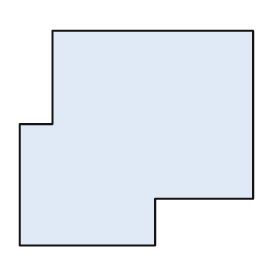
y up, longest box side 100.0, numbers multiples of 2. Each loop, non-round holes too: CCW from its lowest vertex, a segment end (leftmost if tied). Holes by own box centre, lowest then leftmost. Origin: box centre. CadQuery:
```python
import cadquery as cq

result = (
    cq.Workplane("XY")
    .moveTo(-50.0, -46.0)
    .lineTo(8.0, -46.0)
    .lineTo(8.0, -26.0)
    .lineTo(50.0, -26.0)
    .lineTo(50.0, 46.0)
    .lineTo(-36.0, 46.0)
    .lineTo(-36.0, 6.0)
    .lineTo(-50.0, 6.0)
    .close()
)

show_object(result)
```